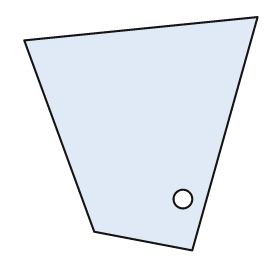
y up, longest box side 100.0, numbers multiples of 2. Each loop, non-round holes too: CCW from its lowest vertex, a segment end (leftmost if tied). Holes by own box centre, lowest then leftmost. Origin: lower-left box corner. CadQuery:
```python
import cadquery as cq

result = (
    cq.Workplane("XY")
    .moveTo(72.0, 0.0)
    .lineTo(100.0, 100.0)
    .lineTo(0.0, 90.0)
    .lineTo(30.0, 8.0)
    .close()
    .moveTo(68.0, 22.0)
    .circle(4.0)
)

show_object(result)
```